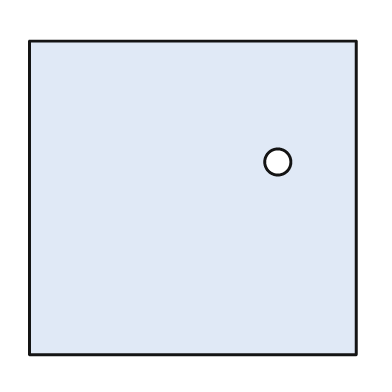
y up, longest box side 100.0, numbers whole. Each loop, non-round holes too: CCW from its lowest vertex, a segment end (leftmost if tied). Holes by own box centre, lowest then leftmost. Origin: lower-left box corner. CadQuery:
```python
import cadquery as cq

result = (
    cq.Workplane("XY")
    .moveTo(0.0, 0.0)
    .lineTo(100.0, 0.0)
    .lineTo(100.0, 96.0)
    .lineTo(0.0, 96.0)
    .close()
    .moveTo(76.0, 59.0)
    .circle(4.0)
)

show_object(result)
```